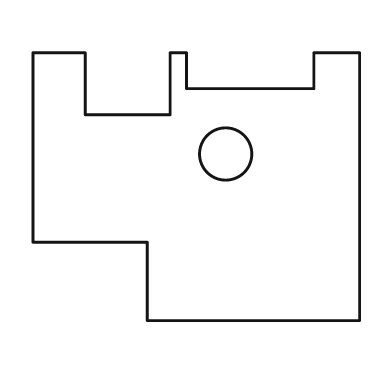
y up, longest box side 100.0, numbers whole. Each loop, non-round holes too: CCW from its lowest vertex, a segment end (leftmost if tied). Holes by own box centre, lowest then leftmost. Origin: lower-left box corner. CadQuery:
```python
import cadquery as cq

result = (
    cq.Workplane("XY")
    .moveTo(35.0, 0.0)
    .lineTo(100.0, 0.0)
    .lineTo(100.0, 82.0)
    .lineTo(86.0, 82.0)
    .lineTo(86.0, 71.0)
    .lineTo(47.0, 71.0)
    .lineTo(47.0, 82.0)
    .lineTo(42.0, 82.0)
    .lineTo(42.0, 63.0)
    .lineTo(16.0, 63.0)
    .lineTo(16.0, 82.0)
    .lineTo(0.0, 82.0)
    .lineTo(0.0, 24.0)
    .lineTo(35.0, 24.0)
    .close()
    .moveTo(59.0, 51.0)
    .circle(8.0)
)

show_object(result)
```